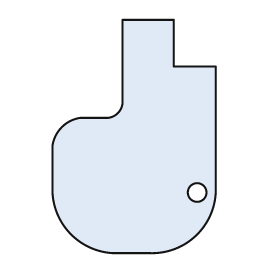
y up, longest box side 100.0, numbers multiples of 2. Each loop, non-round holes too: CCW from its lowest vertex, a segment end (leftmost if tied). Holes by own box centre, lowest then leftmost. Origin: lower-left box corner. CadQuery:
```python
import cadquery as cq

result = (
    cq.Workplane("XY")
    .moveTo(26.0, 0.0)
    .lineTo(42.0, 0.0)
    .threePointArc((62.0, 8.0), (70.0, 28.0))
    .lineTo(70.0, 80.0)
    .lineTo(52.0, 80.0)
    .lineTo(52.0, 100.0)
    .lineTo(30.0, 100.0)
    .lineTo(30.0, 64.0)
    .threePointArc((28.0, 60.0), (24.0, 58.0))
    .lineTo(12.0, 58.0)
    .threePointArc((4.0, 54.0), (0.0, 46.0))
    .lineTo(0.0, 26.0)
    .threePointArc((8.0, 8.0), (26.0, 0.0))
    .close()
    .moveTo(62.0, 26.0)
    .circle(4.0)
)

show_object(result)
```